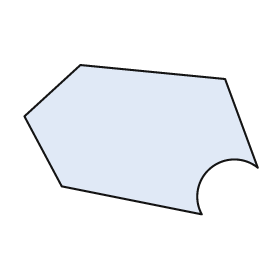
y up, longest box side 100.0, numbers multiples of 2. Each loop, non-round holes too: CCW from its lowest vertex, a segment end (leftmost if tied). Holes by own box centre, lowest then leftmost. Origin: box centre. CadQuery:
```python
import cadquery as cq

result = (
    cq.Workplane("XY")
    .moveTo(26.0, -32.0)
    .threePointArc((30.0, -12.0), (50.0, -12.0))
    .lineTo(36.0, 26.0)
    .lineTo(-26.0, 32.0)
    .lineTo(-50.0, 10.0)
    .lineTo(-34.0, -20.0)
    .close()
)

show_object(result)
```